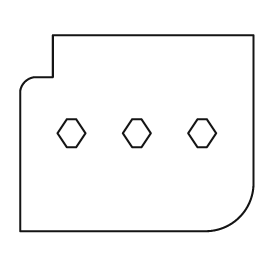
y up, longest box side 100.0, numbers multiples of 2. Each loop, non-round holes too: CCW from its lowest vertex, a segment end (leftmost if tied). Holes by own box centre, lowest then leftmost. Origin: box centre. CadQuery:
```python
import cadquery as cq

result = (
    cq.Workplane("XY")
    .moveTo(-50.0, -42.0)
    .lineTo(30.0, -42.0)
    .threePointArc((44.0, -36.0), (50.0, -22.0))
    .lineTo(50.0, 42.0)
    .lineTo(-36.0, 42.0)
    .lineTo(-36.0, 24.0)
    .lineTo(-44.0, 24.0)
    .threePointArc((-48.0, 22.0), (-50.0, 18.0))
    .close()
    .moveTo(-30.0, -6.0)
    .lineTo(-26.0, -6.0)
    .lineTo(-22.0, 0.0)
    .lineTo(-26.0, 6.0)
    .lineTo(-30.0, 6.0)
    .lineTo(-34.0, 0.0)
    .close()
    .moveTo(-2.0, -6.0)
    .lineTo(2.0, -6.0)
    .lineTo(6.0, 0.0)
    .lineTo(2.0, 6.0)
    .lineTo(-2.0, 6.0)
    .lineTo(-6.0, 0.0)
    .close()
    .moveTo(26.0, -6.0)
    .lineTo(30.0, -6.0)
    .lineTo(34.0, 0.0)
    .lineTo(30.0, 6.0)
    .lineTo(26.0, 6.0)
    .lineTo(22.0, 0.0)
    .close()
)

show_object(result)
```